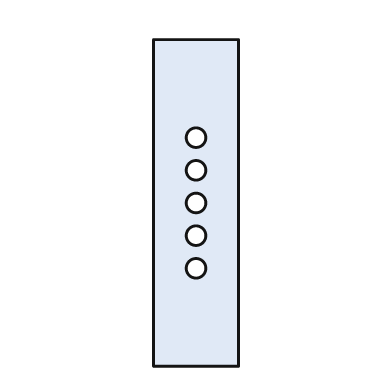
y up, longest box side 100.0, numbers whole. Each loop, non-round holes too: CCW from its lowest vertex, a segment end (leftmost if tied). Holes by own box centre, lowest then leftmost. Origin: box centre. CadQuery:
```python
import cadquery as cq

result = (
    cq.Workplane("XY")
    .moveTo(-13.0, -50.0)
    .lineTo(13.0, -50.0)
    .lineTo(13.0, 50.0)
    .lineTo(-13.0, 50.0)
    .close()
    .moveTo(0.0, -20.0)
    .circle(3.0)
    .moveTo(0.0, -10.0)
    .circle(3.0)
    .moveTo(0.0, 0.0)
    .circle(3.0)
    .moveTo(0.0, 10.0)
    .circle(3.0)
    .moveTo(0.0, 20.0)
    .circle(3.0)
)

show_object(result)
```